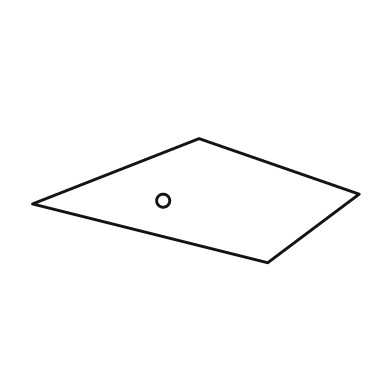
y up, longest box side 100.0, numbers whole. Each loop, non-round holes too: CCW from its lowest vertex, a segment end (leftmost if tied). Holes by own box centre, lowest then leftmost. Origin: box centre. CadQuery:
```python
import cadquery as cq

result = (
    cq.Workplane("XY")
    .moveTo(22.0, -19.0)
    .lineTo(50.0, 2.0)
    .lineTo(1.0, 19.0)
    .lineTo(-50.0, -1.0)
    .close()
    .moveTo(-10.0, 0.0)
    .circle(2.0)
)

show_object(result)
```